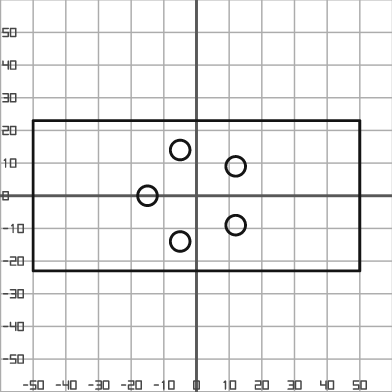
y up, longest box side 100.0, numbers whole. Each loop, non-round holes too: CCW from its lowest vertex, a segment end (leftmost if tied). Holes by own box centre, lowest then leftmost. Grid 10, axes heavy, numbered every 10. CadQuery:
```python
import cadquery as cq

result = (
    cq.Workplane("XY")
    .moveTo(-50.0, -23.0)
    .lineTo(50.0, -23.0)
    .lineTo(50.0, 23.0)
    .lineTo(-50.0, 23.0)
    .close()
    .moveTo(-5.0, -14.0)
    .circle(3.0)
    .moveTo(12.0, -9.0)
    .circle(3.0)
    .moveTo(-15.0, 0.0)
    .circle(3.0)
    .moveTo(12.0, 9.0)
    .circle(3.0)
    .moveTo(-5.0, 14.0)
    .circle(3.0)
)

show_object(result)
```